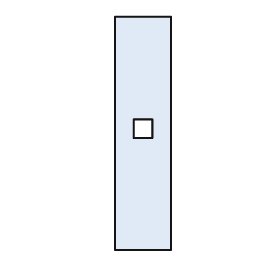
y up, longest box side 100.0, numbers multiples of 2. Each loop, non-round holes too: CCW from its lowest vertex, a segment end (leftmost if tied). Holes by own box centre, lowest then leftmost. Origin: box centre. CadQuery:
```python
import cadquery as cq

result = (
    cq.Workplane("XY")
    .moveTo(-12.0, -50.0)
    .lineTo(12.0, -50.0)
    .lineTo(12.0, 50.0)
    .lineTo(-12.0, 50.0)
    .close()
    .moveTo(-4.0, -2.0)
    .lineTo(4.0, -2.0)
    .lineTo(4.0, 6.0)
    .lineTo(-4.0, 6.0)
    .close()
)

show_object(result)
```